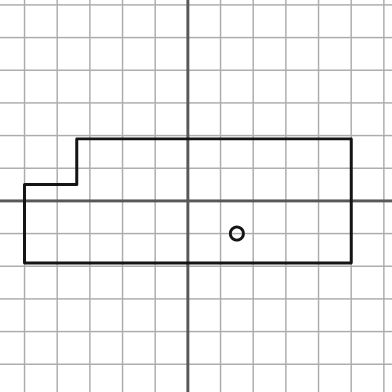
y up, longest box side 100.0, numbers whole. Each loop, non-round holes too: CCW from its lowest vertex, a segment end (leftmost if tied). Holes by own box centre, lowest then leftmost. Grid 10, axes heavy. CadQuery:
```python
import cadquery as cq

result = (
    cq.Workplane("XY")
    .moveTo(-50.0, -19.0)
    .lineTo(50.0, -19.0)
    .lineTo(50.0, 19.0)
    .lineTo(-34.0, 19.0)
    .lineTo(-34.0, 5.0)
    .lineTo(-50.0, 5.0)
    .close()
    .moveTo(15.0, -10.0)
    .circle(2.0)
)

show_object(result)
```